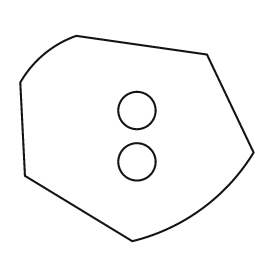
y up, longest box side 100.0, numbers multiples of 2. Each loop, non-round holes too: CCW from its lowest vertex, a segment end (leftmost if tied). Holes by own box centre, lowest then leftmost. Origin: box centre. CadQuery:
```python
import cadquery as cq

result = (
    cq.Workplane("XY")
    .moveTo(-2.0, -44.0)
    .threePointArc((28.0, -30.0), (50.0, -6.0))
    .lineTo(30.0, 36.0)
    .lineTo(-26.0, 44.0)
    .threePointArc((-40.0, 36.0), (-50.0, 24.0))
    .lineTo(-48.0, -16.0)
    .close()
    .moveTo(0.0, -10.0)
    .circle(8.0)
    .moveTo(0.0, 12.0)
    .circle(8.0)
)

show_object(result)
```